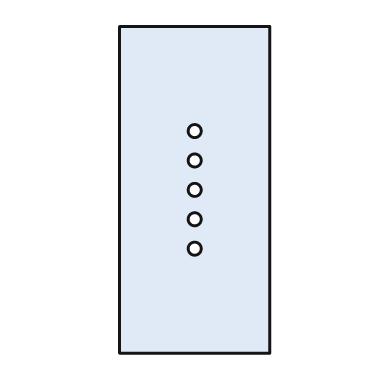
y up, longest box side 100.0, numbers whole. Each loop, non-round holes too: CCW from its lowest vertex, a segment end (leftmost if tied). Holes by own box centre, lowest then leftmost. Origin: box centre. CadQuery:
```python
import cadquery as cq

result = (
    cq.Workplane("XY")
    .moveTo(-23.0, -50.0)
    .lineTo(23.0, -50.0)
    .lineTo(23.0, 50.0)
    .lineTo(-23.0, 50.0)
    .close()
    .moveTo(0.0, -18.0)
    .circle(2.0)
    .moveTo(0.0, -9.0)
    .circle(2.0)
    .moveTo(0.0, 0.0)
    .circle(2.0)
    .moveTo(0.0, 9.0)
    .circle(2.0)
    .moveTo(0.0, 18.0)
    .circle(2.0)
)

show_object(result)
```